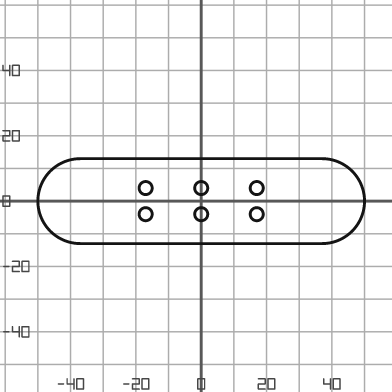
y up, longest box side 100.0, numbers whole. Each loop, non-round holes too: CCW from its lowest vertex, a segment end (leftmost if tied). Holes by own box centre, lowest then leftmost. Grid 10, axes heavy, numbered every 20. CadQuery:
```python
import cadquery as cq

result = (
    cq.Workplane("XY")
    .moveTo(-37.0, -13.0)
    .lineTo(37.0, -13.0)
    .threePointArc((50.0, 0.0), (37.0, 13.0))
    .lineTo(-37.0, 13.0)
    .threePointArc((-50.0, 0.0), (-37.0, -13.0))
    .close()
    .moveTo(-17.0, -4.0)
    .circle(2.0)
    .moveTo(0.0, -4.0)
    .circle(2.0)
    .moveTo(17.0, -4.0)
    .circle(2.0)
    .moveTo(-17.0, 4.0)
    .circle(2.0)
    .moveTo(0.0, 4.0)
    .circle(2.0)
    .moveTo(17.0, 4.0)
    .circle(2.0)
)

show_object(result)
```